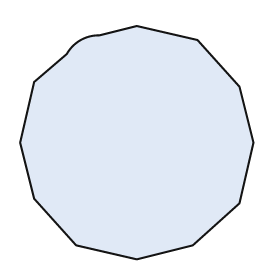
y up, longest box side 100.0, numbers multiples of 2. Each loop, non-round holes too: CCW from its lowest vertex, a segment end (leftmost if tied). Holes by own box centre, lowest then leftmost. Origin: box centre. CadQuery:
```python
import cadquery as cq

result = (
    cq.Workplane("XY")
    .moveTo(0.0, -50.0)
    .lineTo(24.0, -44.0)
    .lineTo(44.0, -26.0)
    .lineTo(50.0, 0.0)
    .lineTo(44.0, 24.0)
    .lineTo(26.0, 44.0)
    .lineTo(0.0, 50.0)
    .lineTo(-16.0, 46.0)
    .threePointArc((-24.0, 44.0), (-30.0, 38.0))
    .lineTo(-44.0, 26.0)
    .lineTo(-50.0, 0.0)
    .lineTo(-44.0, -24.0)
    .lineTo(-26.0, -44.0)
    .close()
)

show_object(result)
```